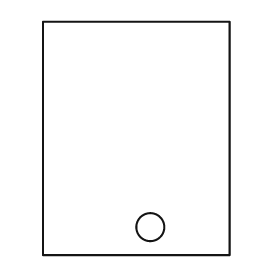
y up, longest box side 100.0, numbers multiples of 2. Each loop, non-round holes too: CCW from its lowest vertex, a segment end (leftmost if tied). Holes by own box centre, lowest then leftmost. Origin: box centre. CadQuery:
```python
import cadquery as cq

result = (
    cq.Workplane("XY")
    .moveTo(-40.0, -50.0)
    .lineTo(40.0, -50.0)
    .lineTo(40.0, 50.0)
    .lineTo(-40.0, 50.0)
    .close()
    .moveTo(6.0, -38.0)
    .circle(6.0)
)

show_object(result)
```